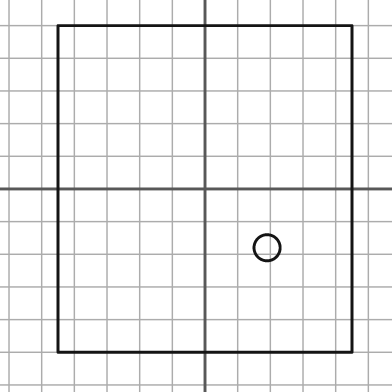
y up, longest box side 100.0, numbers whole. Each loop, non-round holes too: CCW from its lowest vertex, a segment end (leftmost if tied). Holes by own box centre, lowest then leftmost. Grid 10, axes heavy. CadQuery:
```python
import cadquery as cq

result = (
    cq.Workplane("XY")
    .moveTo(-45.0, -50.0)
    .lineTo(45.0, -50.0)
    .lineTo(45.0, 50.0)
    .lineTo(-45.0, 50.0)
    .close()
    .moveTo(19.0, -18.0)
    .circle(4.0)
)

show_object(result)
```